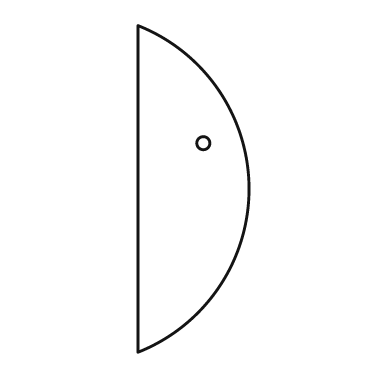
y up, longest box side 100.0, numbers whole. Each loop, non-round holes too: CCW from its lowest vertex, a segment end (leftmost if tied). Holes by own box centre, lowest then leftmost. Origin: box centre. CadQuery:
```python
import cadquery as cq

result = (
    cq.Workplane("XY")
    .moveTo(-17.0, -50.0)
    .threePointArc((17.0, 0.0), (-17.0, 50.0))
    .close()
    .moveTo(3.0, 14.0)
    .circle(2.0)
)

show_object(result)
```